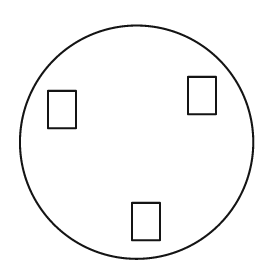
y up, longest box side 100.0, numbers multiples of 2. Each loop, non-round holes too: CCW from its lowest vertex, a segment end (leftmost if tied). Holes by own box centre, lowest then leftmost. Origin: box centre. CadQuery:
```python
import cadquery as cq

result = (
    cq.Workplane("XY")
    .moveTo(0.0, 0.0)
    .circle(50.0)
    .moveTo(-2.0, -42.0)
    .lineTo(10.0, -42.0)
    .lineTo(10.0, -26.0)
    .lineTo(-2.0, -26.0)
    .close()
    .moveTo(-38.0, 6.0)
    .lineTo(-26.0, 6.0)
    .lineTo(-26.0, 22.0)
    .lineTo(-38.0, 22.0)
    .close()
    .moveTo(22.0, 12.0)
    .lineTo(34.0, 12.0)
    .lineTo(34.0, 28.0)
    .lineTo(22.0, 28.0)
    .close()
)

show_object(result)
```